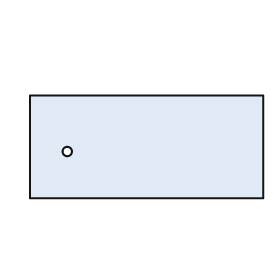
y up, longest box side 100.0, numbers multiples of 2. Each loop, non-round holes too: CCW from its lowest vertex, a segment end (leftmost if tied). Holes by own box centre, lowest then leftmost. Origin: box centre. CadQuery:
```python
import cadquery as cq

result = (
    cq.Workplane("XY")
    .moveTo(-50.0, -22.0)
    .lineTo(50.0, -22.0)
    .lineTo(50.0, 22.0)
    .lineTo(-50.0, 22.0)
    .close()
    .moveTo(-34.0, -2.0)
    .circle(2.0)
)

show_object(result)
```